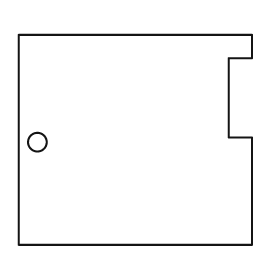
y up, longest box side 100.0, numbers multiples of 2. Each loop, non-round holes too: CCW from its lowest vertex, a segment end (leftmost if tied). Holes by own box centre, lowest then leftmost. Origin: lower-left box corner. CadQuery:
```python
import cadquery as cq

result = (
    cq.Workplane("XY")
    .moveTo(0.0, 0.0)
    .lineTo(100.0, 0.0)
    .lineTo(100.0, 46.0)
    .lineTo(90.0, 46.0)
    .lineTo(90.0, 80.0)
    .lineTo(100.0, 80.0)
    .lineTo(100.0, 90.0)
    .lineTo(0.0, 90.0)
    .close()
    .moveTo(8.0, 44.0)
    .circle(4.0)
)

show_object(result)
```